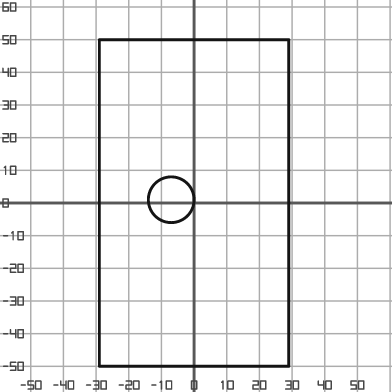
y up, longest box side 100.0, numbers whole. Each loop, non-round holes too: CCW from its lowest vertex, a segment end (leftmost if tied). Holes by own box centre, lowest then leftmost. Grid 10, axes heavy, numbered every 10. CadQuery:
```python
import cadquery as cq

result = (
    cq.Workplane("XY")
    .moveTo(-29.0, -50.0)
    .lineTo(29.0, -50.0)
    .lineTo(29.0, 50.0)
    .lineTo(-29.0, 50.0)
    .close()
    .moveTo(-7.0, 1.0)
    .circle(7.0)
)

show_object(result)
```